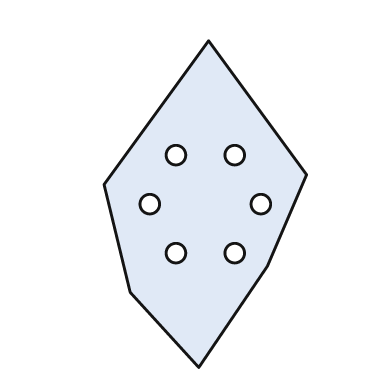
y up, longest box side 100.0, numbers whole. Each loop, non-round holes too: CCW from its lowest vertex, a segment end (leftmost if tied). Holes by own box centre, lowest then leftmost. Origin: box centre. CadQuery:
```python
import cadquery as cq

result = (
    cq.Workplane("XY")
    .moveTo(-2.0, -50.0)
    .lineTo(19.0, -19.0)
    .lineTo(31.0, 9.0)
    .lineTo(1.0, 50.0)
    .lineTo(-31.0, 6.0)
    .lineTo(-23.0, -27.0)
    .close()
    .moveTo(-9.0, -15.0)
    .circle(3.0)
    .moveTo(9.0, -15.0)
    .circle(3.0)
    .moveTo(-17.0, 0.0)
    .circle(3.0)
    .moveTo(17.0, 0.0)
    .circle(3.0)
    .moveTo(-9.0, 15.0)
    .circle(3.0)
    .moveTo(9.0, 15.0)
    .circle(3.0)
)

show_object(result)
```